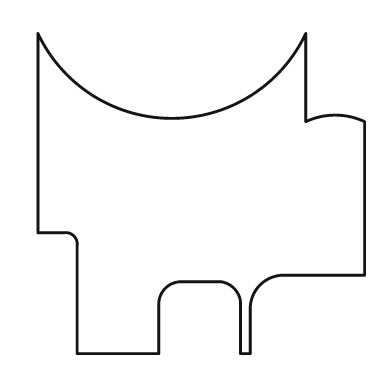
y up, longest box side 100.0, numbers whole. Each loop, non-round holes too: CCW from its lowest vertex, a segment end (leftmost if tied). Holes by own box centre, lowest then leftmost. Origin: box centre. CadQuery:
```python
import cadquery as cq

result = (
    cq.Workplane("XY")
    .moveTo(-38.0, -49.0)
    .lineTo(-13.0, -49.0)
    .lineTo(-13.0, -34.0)
    .threePointArc((-11.0, -29.0), (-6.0, -27.0))
    .lineTo(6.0, -27.0)
    .threePointArc((10.0, -29.0), (12.0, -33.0))
    .lineTo(12.0, -49.0)
    .lineTo(15.0, -49.0)
    .lineTo(15.0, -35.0)
    .threePointArc((18.0, -28.0), (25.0, -25.0))
    .lineTo(50.0, -25.0)
    .lineTo(50.0, 22.0)
    .threePointArc((41.0, 24.0), (32.0, 22.0))
    .lineTo(32.0, 49.0)
    .threePointArc((-9.0, 23.0), (-50.0, 49.0))
    .lineTo(-50.0, -12.0)
    .lineTo(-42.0, -12.0)
    .threePointArc((-39.0, -13.0), (-38.0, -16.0))
    .close()
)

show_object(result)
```